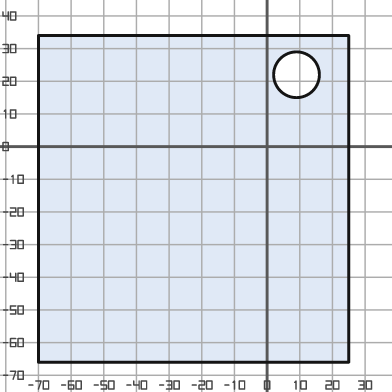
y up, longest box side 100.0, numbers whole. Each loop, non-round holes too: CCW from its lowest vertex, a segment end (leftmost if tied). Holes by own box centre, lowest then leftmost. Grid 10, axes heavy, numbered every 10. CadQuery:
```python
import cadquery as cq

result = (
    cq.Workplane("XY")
    .moveTo(-70.0, -66.0)
    .lineTo(25.0, -66.0)
    .lineTo(25.0, 34.0)
    .lineTo(-70.0, 34.0)
    .close()
    .moveTo(9.0, 22.0)
    .circle(7.0)
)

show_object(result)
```